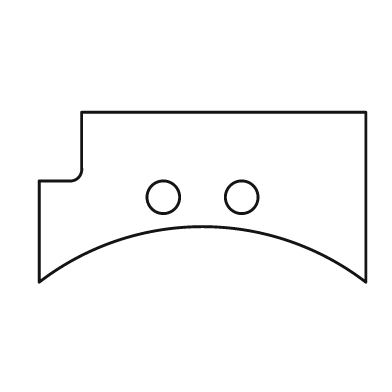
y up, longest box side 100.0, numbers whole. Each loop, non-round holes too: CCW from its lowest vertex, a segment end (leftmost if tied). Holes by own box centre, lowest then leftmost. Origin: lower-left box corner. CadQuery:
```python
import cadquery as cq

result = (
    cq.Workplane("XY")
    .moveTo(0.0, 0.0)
    .threePointArc((50.0, 17.0), (100.0, 0.0))
    .lineTo(100.0, 52.0)
    .lineTo(13.0, 52.0)
    .lineTo(13.0, 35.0)
    .threePointArc((12.0, 32.0), (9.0, 31.0))
    .lineTo(0.0, 31.0)
    .close()
    .moveTo(38.0, 26.0)
    .circle(5.0)
    .moveTo(62.0, 26.0)
    .circle(5.0)
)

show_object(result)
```